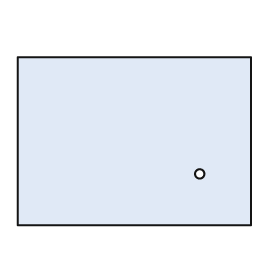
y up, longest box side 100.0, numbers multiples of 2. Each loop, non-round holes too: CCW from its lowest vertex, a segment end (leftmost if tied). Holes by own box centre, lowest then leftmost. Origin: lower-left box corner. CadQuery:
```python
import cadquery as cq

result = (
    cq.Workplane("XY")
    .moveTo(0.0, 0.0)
    .lineTo(100.0, 0.0)
    .lineTo(100.0, 72.0)
    .lineTo(0.0, 72.0)
    .close()
    .moveTo(78.0, 22.0)
    .circle(2.0)
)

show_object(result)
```